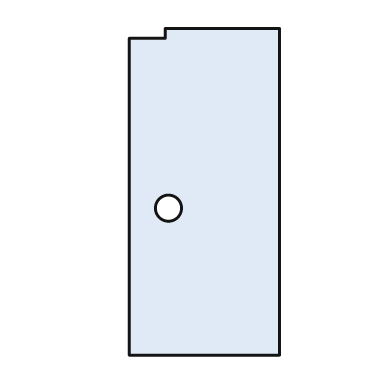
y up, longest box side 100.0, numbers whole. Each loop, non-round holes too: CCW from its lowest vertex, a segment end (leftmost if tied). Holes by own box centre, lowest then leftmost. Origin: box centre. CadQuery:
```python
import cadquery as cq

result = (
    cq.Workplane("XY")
    .moveTo(-23.0, -50.0)
    .lineTo(23.0, -50.0)
    .lineTo(23.0, 50.0)
    .lineTo(-12.0, 50.0)
    .lineTo(-12.0, 47.0)
    .lineTo(-23.0, 47.0)
    .close()
    .moveTo(-11.0, -5.0)
    .circle(4.0)
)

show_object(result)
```